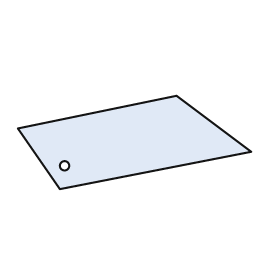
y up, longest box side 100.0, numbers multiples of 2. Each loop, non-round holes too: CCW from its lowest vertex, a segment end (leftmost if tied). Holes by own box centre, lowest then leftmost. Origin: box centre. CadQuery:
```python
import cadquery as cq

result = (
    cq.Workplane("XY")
    .moveTo(-32.0, -20.0)
    .lineTo(50.0, -4.0)
    .lineTo(18.0, 20.0)
    .lineTo(-50.0, 6.0)
    .close()
    .moveTo(-30.0, -10.0)
    .circle(2.0)
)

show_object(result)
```